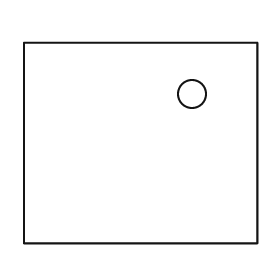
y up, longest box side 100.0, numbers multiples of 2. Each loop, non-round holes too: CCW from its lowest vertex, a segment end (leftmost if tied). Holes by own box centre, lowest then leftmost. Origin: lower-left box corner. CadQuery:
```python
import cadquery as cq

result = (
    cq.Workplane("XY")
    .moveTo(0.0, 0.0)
    .lineTo(100.0, 0.0)
    .lineTo(100.0, 86.0)
    .lineTo(0.0, 86.0)
    .close()
    .moveTo(72.0, 64.0)
    .circle(6.0)
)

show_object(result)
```